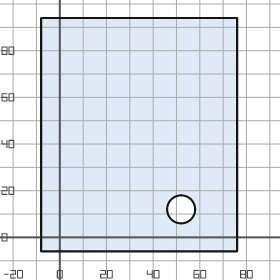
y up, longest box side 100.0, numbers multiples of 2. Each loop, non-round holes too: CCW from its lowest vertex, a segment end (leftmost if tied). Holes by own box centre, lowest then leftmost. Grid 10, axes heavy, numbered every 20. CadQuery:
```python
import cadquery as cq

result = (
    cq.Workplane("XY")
    .moveTo(-8.0, -6.0)
    .lineTo(76.0, -6.0)
    .lineTo(76.0, 94.0)
    .lineTo(-8.0, 94.0)
    .close()
    .moveTo(52.0, 12.0)
    .circle(6.0)
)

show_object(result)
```